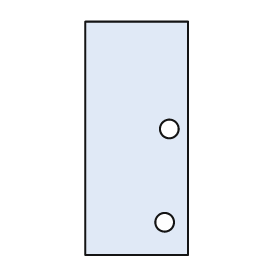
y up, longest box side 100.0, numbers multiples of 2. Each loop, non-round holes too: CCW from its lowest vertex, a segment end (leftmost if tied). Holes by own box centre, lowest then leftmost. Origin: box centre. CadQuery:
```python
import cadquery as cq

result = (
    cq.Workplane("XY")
    .moveTo(-22.0, -50.0)
    .lineTo(22.0, -50.0)
    .lineTo(22.0, 50.0)
    .lineTo(-22.0, 50.0)
    .close()
    .moveTo(12.0, -36.0)
    .circle(4.0)
    .moveTo(14.0, 4.0)
    .circle(4.0)
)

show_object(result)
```